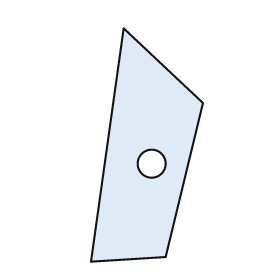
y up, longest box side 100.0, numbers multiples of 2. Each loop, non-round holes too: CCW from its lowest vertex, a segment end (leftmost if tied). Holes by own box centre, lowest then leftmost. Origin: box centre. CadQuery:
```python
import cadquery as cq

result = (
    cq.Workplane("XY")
    .moveTo(-24.0, -50.0)
    .lineTo(8.0, -48.0)
    .lineTo(24.0, 18.0)
    .lineTo(-10.0, 50.0)
    .close()
    .moveTo(2.0, -8.0)
    .circle(6.0)
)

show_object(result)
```